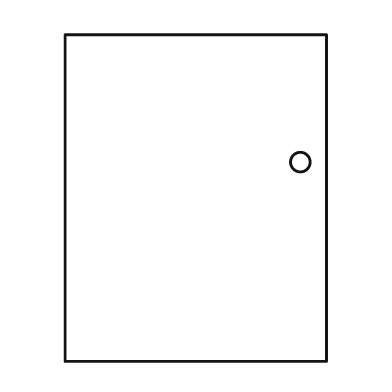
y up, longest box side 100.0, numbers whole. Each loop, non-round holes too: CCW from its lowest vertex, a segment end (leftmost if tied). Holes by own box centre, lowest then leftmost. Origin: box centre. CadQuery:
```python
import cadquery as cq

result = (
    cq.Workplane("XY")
    .moveTo(-40.0, -50.0)
    .lineTo(40.0, -50.0)
    .lineTo(40.0, 50.0)
    .lineTo(-40.0, 50.0)
    .close()
    .moveTo(32.0, 11.0)
    .circle(3.0)
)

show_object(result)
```